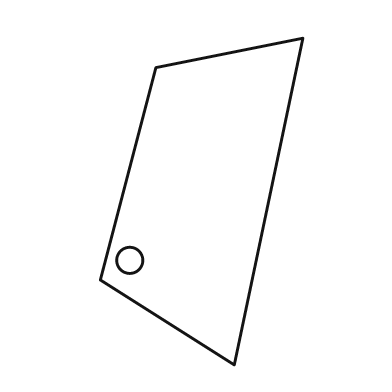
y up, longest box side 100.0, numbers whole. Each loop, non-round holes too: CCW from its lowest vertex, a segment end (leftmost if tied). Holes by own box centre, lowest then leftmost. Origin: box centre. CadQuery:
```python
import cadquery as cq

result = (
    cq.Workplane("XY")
    .moveTo(10.0, -50.0)
    .lineTo(31.0, 50.0)
    .lineTo(-14.0, 41.0)
    .lineTo(-31.0, -24.0)
    .close()
    .moveTo(-22.0, -18.0)
    .circle(4.0)
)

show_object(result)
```